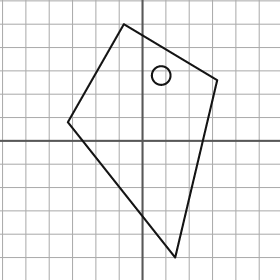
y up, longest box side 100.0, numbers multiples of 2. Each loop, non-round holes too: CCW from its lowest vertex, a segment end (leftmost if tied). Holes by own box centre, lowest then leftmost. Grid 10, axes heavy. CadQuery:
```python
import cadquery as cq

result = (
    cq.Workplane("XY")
    .moveTo(14.0, -50.0)
    .lineTo(32.0, 26.0)
    .lineTo(-8.0, 50.0)
    .lineTo(-32.0, 8.0)
    .close()
    .moveTo(8.0, 28.0)
    .circle(4.0)
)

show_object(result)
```